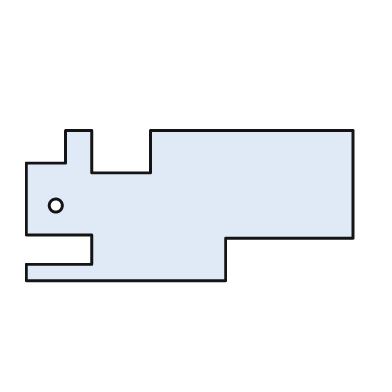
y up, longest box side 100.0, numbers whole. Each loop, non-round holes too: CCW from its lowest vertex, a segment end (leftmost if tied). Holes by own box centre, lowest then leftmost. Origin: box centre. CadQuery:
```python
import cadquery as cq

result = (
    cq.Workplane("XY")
    .moveTo(-50.0, -23.0)
    .lineTo(11.0, -23.0)
    .lineTo(11.0, -10.0)
    .lineTo(50.0, -10.0)
    .lineTo(50.0, 23.0)
    .lineTo(-12.0, 23.0)
    .lineTo(-12.0, 10.0)
    .lineTo(-30.0, 10.0)
    .lineTo(-30.0, 23.0)
    .lineTo(-38.0, 23.0)
    .lineTo(-38.0, 13.0)
    .lineTo(-50.0, 13.0)
    .lineTo(-50.0, -9.0)
    .lineTo(-30.0, -9.0)
    .lineTo(-30.0, -18.0)
    .lineTo(-50.0, -18.0)
    .close()
    .moveTo(-41.0, 0.0)
    .circle(2.0)
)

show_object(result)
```